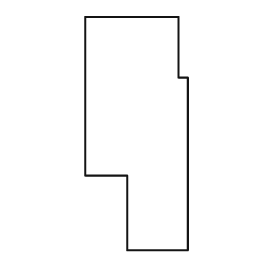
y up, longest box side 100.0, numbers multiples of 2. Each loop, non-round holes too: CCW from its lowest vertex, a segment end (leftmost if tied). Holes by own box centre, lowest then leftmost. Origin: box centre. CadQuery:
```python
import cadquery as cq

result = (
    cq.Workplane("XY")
    .moveTo(-4.0, -50.0)
    .lineTo(22.0, -50.0)
    .lineTo(22.0, 24.0)
    .lineTo(18.0, 24.0)
    .lineTo(18.0, 50.0)
    .lineTo(-22.0, 50.0)
    .lineTo(-22.0, -18.0)
    .lineTo(-4.0, -18.0)
    .close()
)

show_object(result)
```